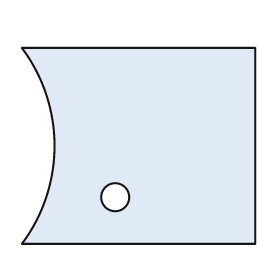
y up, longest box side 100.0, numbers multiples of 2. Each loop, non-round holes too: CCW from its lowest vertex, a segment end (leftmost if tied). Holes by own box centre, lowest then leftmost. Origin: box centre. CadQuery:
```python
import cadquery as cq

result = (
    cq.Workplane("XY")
    .moveTo(-50.0, -42.0)
    .lineTo(50.0, -42.0)
    .lineTo(50.0, 42.0)
    .lineTo(-50.0, 42.0)
    .threePointArc((-36.0, 0.0), (-50.0, -42.0))
    .close()
    .moveTo(-10.0, -22.0)
    .circle(6.0)
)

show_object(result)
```